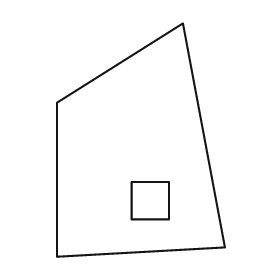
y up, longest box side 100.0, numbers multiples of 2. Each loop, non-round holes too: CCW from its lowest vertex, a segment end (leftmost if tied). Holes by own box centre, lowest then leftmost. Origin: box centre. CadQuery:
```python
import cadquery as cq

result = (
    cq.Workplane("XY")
    .moveTo(-36.0, -50.0)
    .lineTo(36.0, -46.0)
    .lineTo(18.0, 50.0)
    .lineTo(-36.0, 16.0)
    .close()
    .moveTo(-4.0, -34.0)
    .lineTo(12.0, -34.0)
    .lineTo(12.0, -18.0)
    .lineTo(-4.0, -18.0)
    .close()
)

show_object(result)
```